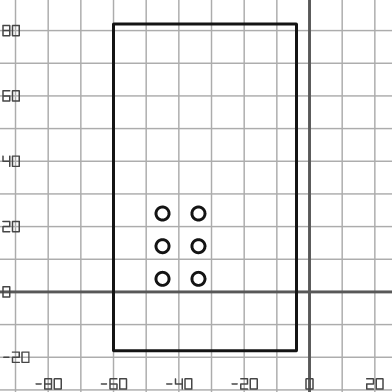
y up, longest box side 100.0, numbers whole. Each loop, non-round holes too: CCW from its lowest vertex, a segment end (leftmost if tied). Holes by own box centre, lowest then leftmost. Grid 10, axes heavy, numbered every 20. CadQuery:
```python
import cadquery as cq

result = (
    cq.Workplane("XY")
    .moveTo(-60.0, -18.0)
    .lineTo(-4.0, -18.0)
    .lineTo(-4.0, 82.0)
    .lineTo(-60.0, 82.0)
    .close()
    .moveTo(-45.0, 4.0)
    .circle(2.0)
    .moveTo(-34.0, 4.0)
    .circle(2.0)
    .moveTo(-45.0, 14.0)
    .circle(2.0)
    .moveTo(-34.0, 14.0)
    .circle(2.0)
    .moveTo(-45.0, 24.0)
    .circle(2.0)
    .moveTo(-34.0, 24.0)
    .circle(2.0)
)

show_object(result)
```